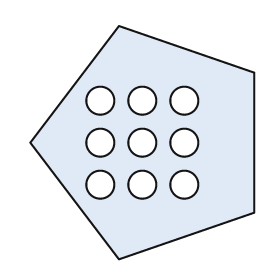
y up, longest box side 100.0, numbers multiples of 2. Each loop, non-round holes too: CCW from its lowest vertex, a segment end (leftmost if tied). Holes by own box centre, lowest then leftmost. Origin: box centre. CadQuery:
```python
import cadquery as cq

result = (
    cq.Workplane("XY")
    .moveTo(-10.0, -50.0)
    .lineTo(48.0, -30.0)
    .lineTo(48.0, 30.0)
    .lineTo(-10.0, 50.0)
    .lineTo(-48.0, 0.0)
    .close()
    .moveTo(-18.0, -18.0)
    .circle(6.0)
    .moveTo(0.0, -18.0)
    .circle(6.0)
    .moveTo(18.0, -18.0)
    .circle(6.0)
    .moveTo(-18.0, 0.0)
    .circle(6.0)
    .moveTo(0.0, 0.0)
    .circle(6.0)
    .moveTo(18.0, 0.0)
    .circle(6.0)
    .moveTo(-18.0, 18.0)
    .circle(6.0)
    .moveTo(0.0, 18.0)
    .circle(6.0)
    .moveTo(18.0, 18.0)
    .circle(6.0)
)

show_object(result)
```